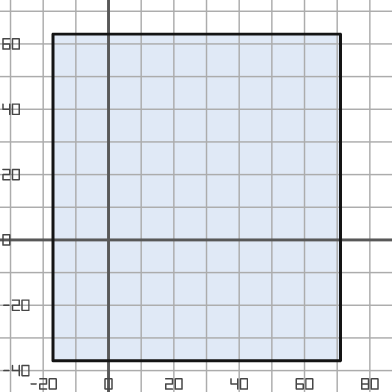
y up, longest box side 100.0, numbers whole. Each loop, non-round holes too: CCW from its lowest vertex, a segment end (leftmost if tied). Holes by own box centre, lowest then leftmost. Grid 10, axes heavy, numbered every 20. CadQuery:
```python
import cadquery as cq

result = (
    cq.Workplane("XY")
    .moveTo(-17.0, -37.0)
    .lineTo(71.0, -37.0)
    .lineTo(71.0, 63.0)
    .lineTo(-17.0, 63.0)
    .close()
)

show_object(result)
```